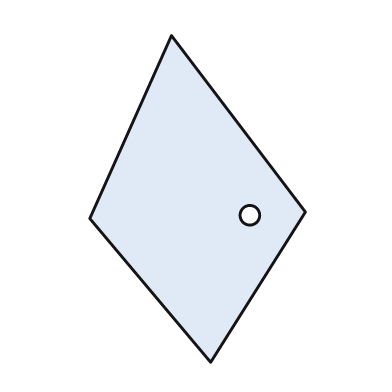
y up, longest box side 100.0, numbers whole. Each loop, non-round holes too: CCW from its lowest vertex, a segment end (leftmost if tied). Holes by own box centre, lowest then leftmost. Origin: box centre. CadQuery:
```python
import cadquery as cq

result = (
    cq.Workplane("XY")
    .moveTo(4.0, -50.0)
    .lineTo(33.0, -4.0)
    .lineTo(-8.0, 50.0)
    .lineTo(-33.0, -6.0)
    .close()
    .moveTo(16.0, -5.0)
    .circle(3.0)
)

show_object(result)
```